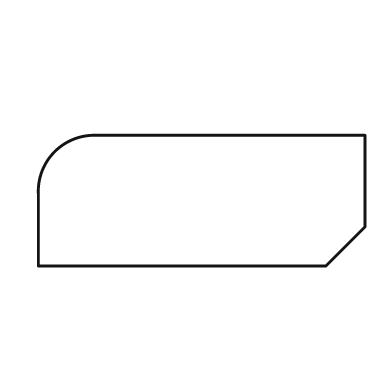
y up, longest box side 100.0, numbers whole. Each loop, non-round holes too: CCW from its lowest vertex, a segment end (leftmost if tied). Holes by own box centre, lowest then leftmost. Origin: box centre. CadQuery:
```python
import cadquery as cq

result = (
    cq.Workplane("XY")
    .moveTo(-50.0, -20.0)
    .lineTo(38.0, -20.0)
    .lineTo(50.0, -8.0)
    .lineTo(50.0, 20.0)
    .lineTo(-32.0, 20.0)
    .threePointArc((-45.0, 15.0), (-50.0, 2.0))
    .close()
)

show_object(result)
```